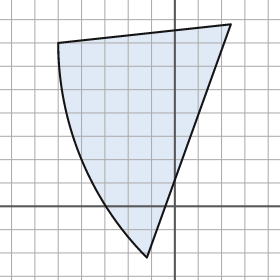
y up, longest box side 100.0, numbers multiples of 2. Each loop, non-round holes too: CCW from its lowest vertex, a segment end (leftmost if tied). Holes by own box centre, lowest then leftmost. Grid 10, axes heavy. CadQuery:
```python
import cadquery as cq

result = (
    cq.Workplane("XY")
    .moveTo(-12.0, -22.0)
    .lineTo(24.0, 78.0)
    .lineTo(-50.0, 70.0)
    .threePointArc((-40.0, 20.0), (-12.0, -22.0))
    .close()
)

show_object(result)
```